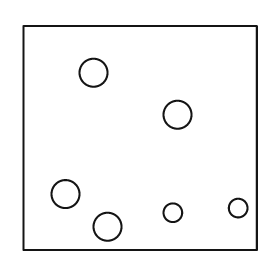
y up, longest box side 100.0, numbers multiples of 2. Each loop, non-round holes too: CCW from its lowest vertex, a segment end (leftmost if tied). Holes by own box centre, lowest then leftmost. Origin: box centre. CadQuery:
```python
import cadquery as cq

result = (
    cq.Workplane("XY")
    .moveTo(-50.0, -48.0)
    .lineTo(50.0, -48.0)
    .lineTo(50.0, 48.0)
    .lineTo(-50.0, 48.0)
    .close()
    .moveTo(-14.0, -38.0)
    .circle(6.0)
    .moveTo(14.0, -32.0)
    .circle(4.0)
    .moveTo(42.0, -30.0)
    .circle(4.0)
    .moveTo(-32.0, -24.0)
    .circle(6.0)
    .moveTo(16.0, 10.0)
    .circle(6.0)
    .moveTo(-20.0, 28.0)
    .circle(6.0)
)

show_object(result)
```